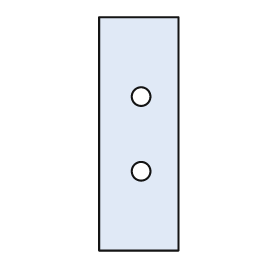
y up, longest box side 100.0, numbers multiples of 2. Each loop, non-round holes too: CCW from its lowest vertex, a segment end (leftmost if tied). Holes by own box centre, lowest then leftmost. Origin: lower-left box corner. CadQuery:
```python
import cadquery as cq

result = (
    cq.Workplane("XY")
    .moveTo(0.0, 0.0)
    .lineTo(34.0, 0.0)
    .lineTo(34.0, 100.0)
    .lineTo(0.0, 100.0)
    .close()
    .moveTo(18.0, 34.0)
    .circle(4.0)
    .moveTo(18.0, 66.0)
    .circle(4.0)
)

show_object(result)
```